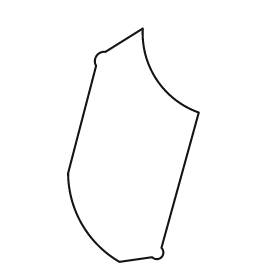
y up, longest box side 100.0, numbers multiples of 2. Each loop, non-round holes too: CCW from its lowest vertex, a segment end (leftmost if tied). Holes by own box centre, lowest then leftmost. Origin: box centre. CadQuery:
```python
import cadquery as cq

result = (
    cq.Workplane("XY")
    .moveTo(-6.0, -50.0)
    .lineTo(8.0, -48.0)
    .threePointArc((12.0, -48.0), (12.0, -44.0))
    .lineTo(28.0, 14.0)
    .threePointArc((10.0, 28.0), (4.0, 50.0))
    .lineTo(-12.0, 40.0)
    .threePointArc((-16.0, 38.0), (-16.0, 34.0))
    .lineTo(-28.0, -12.0)
    .threePointArc((-22.0, -34.0), (-6.0, -50.0))
    .close()
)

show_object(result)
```